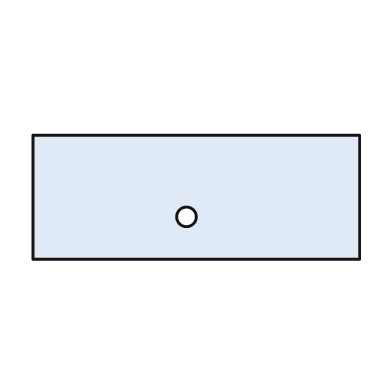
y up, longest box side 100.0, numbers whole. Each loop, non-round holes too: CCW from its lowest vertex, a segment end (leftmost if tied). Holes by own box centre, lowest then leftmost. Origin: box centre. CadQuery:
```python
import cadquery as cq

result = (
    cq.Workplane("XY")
    .moveTo(-50.0, -19.0)
    .lineTo(50.0, -19.0)
    .lineTo(50.0, 19.0)
    .lineTo(-50.0, 19.0)
    .close()
    .moveTo(-3.0, -6.0)
    .circle(3.0)
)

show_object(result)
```